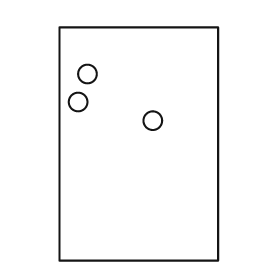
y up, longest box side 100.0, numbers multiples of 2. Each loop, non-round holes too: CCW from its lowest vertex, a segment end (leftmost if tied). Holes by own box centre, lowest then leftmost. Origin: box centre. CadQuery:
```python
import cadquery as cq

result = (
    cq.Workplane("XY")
    .moveTo(-34.0, -50.0)
    .lineTo(34.0, -50.0)
    .lineTo(34.0, 50.0)
    .lineTo(-34.0, 50.0)
    .close()
    .moveTo(6.0, 10.0)
    .circle(4.0)
    .moveTo(-26.0, 18.0)
    .circle(4.0)
    .moveTo(-22.0, 30.0)
    .circle(4.0)
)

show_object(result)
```